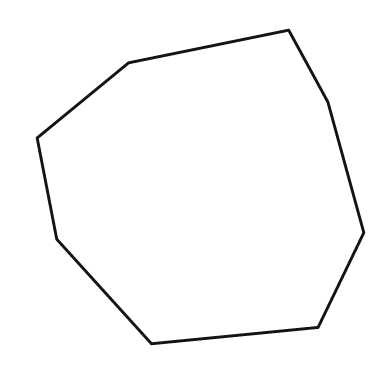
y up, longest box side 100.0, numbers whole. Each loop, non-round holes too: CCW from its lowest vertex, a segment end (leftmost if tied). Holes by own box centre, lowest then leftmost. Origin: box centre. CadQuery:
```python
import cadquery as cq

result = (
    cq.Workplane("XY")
    .moveTo(-15.0, -48.0)
    .lineTo(36.0, -43.0)
    .lineTo(50.0, -14.0)
    .lineTo(39.0, 26.0)
    .lineTo(27.0, 48.0)
    .lineTo(-22.0, 38.0)
    .lineTo(-50.0, 15.0)
    .lineTo(-44.0, -16.0)
    .close()
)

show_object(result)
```